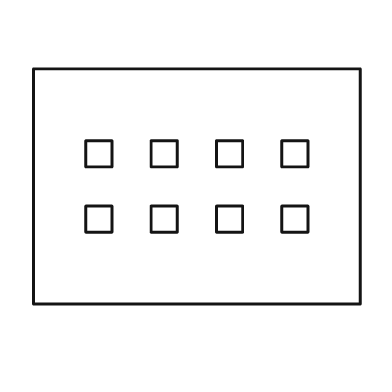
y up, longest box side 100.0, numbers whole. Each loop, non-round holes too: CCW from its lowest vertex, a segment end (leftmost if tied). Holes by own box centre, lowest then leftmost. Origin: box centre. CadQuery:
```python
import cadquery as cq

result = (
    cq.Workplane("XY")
    .moveTo(-50.0, -36.0)
    .lineTo(50.0, -36.0)
    .lineTo(50.0, 36.0)
    .lineTo(-50.0, 36.0)
    .close()
    .moveTo(-34.0, -14.0)
    .lineTo(-26.0, -14.0)
    .lineTo(-26.0, -6.0)
    .lineTo(-34.0, -6.0)
    .close()
    .moveTo(-14.0, -14.0)
    .lineTo(-6.0, -14.0)
    .lineTo(-6.0, -6.0)
    .lineTo(-14.0, -6.0)
    .close()
    .moveTo(6.0, -14.0)
    .lineTo(14.0, -14.0)
    .lineTo(14.0, -6.0)
    .lineTo(6.0, -6.0)
    .close()
    .moveTo(26.0, -14.0)
    .lineTo(34.0, -14.0)
    .lineTo(34.0, -6.0)
    .lineTo(26.0, -6.0)
    .close()
    .moveTo(-34.0, 6.0)
    .lineTo(-26.0, 6.0)
    .lineTo(-26.0, 14.0)
    .lineTo(-34.0, 14.0)
    .close()
    .moveTo(-14.0, 6.0)
    .lineTo(-6.0, 6.0)
    .lineTo(-6.0, 14.0)
    .lineTo(-14.0, 14.0)
    .close()
    .moveTo(6.0, 6.0)
    .lineTo(14.0, 6.0)
    .lineTo(14.0, 14.0)
    .lineTo(6.0, 14.0)
    .close()
    .moveTo(26.0, 6.0)
    .lineTo(34.0, 6.0)
    .lineTo(34.0, 14.0)
    .lineTo(26.0, 14.0)
    .close()
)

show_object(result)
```